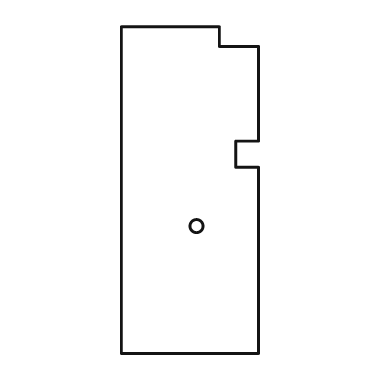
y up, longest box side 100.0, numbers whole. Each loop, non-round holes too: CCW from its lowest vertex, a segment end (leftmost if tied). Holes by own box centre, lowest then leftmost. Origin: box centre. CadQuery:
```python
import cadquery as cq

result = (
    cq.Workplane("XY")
    .moveTo(-21.0, -50.0)
    .lineTo(21.0, -50.0)
    .lineTo(21.0, 7.0)
    .lineTo(14.0, 7.0)
    .lineTo(14.0, 15.0)
    .lineTo(21.0, 15.0)
    .lineTo(21.0, 44.0)
    .lineTo(9.0, 44.0)
    .lineTo(9.0, 50.0)
    .lineTo(-21.0, 50.0)
    .close()
    .moveTo(2.0, -11.0)
    .circle(2.0)
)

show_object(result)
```